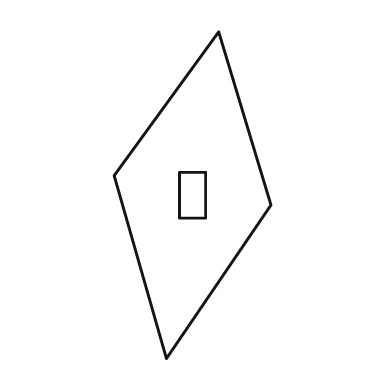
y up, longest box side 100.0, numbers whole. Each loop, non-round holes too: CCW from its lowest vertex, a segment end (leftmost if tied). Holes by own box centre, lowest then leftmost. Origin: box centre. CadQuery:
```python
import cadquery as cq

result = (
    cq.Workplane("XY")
    .moveTo(-8.0, -50.0)
    .lineTo(24.0, -3.0)
    .lineTo(8.0, 50.0)
    .lineTo(-24.0, 6.0)
    .close()
    .moveTo(-4.0, -7.0)
    .lineTo(4.0, -7.0)
    .lineTo(4.0, 7.0)
    .lineTo(-4.0, 7.0)
    .close()
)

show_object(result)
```